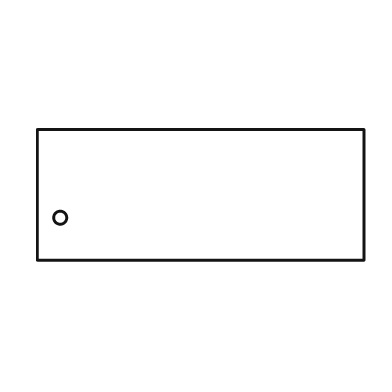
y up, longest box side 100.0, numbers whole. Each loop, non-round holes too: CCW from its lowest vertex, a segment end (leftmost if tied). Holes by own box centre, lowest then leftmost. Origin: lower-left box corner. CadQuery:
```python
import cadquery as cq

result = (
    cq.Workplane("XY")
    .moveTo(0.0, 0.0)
    .lineTo(100.0, 0.0)
    .lineTo(100.0, 40.0)
    .lineTo(0.0, 40.0)
    .close()
    .moveTo(7.0, 13.0)
    .circle(2.0)
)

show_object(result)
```